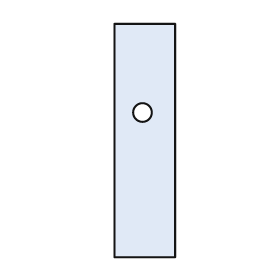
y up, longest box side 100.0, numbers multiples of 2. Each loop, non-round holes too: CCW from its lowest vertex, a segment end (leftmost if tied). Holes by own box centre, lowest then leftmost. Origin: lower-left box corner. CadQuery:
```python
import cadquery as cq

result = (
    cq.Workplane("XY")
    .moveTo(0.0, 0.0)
    .lineTo(26.0, 0.0)
    .lineTo(26.0, 100.0)
    .lineTo(0.0, 100.0)
    .close()
    .moveTo(12.0, 62.0)
    .circle(4.0)
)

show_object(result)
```